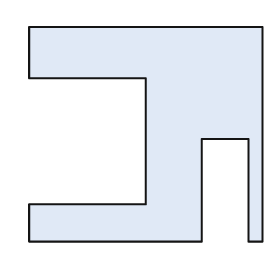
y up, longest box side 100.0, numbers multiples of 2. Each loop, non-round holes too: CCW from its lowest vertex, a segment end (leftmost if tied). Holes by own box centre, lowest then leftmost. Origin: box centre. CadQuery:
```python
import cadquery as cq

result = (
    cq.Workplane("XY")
    .moveTo(-50.0, -46.0)
    .lineTo(24.0, -46.0)
    .lineTo(24.0, -2.0)
    .lineTo(44.0, -2.0)
    .lineTo(44.0, -46.0)
    .lineTo(50.0, -46.0)
    .lineTo(50.0, 46.0)
    .lineTo(-50.0, 46.0)
    .lineTo(-50.0, 24.0)
    .lineTo(0.0, 24.0)
    .lineTo(0.0, -30.0)
    .lineTo(-50.0, -30.0)
    .close()
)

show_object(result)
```